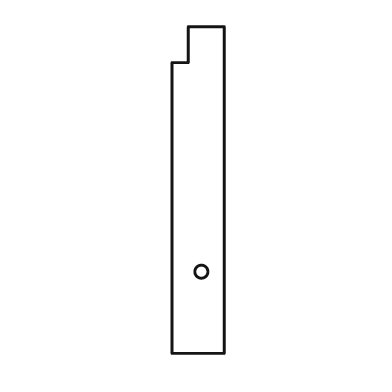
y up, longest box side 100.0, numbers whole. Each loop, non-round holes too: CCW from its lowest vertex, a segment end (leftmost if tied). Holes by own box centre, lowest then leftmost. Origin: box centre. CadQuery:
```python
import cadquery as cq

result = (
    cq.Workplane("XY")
    .moveTo(-8.0, -50.0)
    .lineTo(8.0, -50.0)
    .lineTo(8.0, 50.0)
    .lineTo(-3.0, 50.0)
    .lineTo(-3.0, 39.0)
    .lineTo(-8.0, 39.0)
    .close()
    .moveTo(1.0, -25.0)
    .circle(2.0)
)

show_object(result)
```